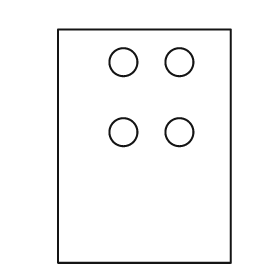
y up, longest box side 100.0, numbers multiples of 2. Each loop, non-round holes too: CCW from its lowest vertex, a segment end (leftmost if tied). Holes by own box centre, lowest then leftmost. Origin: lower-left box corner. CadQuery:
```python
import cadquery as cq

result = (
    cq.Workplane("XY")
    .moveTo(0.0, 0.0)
    .lineTo(74.0, 0.0)
    .lineTo(74.0, 100.0)
    .lineTo(0.0, 100.0)
    .close()
    .moveTo(28.0, 56.0)
    .circle(6.0)
    .moveTo(52.0, 56.0)
    .circle(6.0)
    .moveTo(28.0, 86.0)
    .circle(6.0)
    .moveTo(52.0, 86.0)
    .circle(6.0)
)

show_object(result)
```